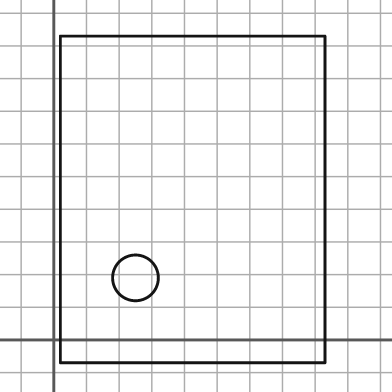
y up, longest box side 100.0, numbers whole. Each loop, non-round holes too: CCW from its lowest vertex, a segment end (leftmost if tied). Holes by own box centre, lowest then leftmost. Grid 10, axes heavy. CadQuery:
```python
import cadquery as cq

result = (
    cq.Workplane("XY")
    .moveTo(2.0, -7.0)
    .lineTo(83.0, -7.0)
    .lineTo(83.0, 93.0)
    .lineTo(2.0, 93.0)
    .close()
    .moveTo(25.0, 19.0)
    .circle(7.0)
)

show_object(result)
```